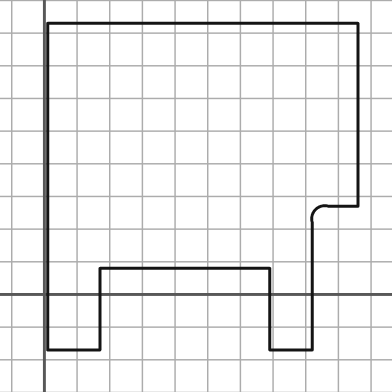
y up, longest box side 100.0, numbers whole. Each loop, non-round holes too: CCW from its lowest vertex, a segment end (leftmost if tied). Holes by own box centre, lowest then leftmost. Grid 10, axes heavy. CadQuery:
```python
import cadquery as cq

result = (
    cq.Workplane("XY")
    .moveTo(1.0, -17.0)
    .lineTo(17.0, -17.0)
    .lineTo(17.0, 8.0)
    .lineTo(69.0, 8.0)
    .lineTo(69.0, -17.0)
    .lineTo(82.0, -17.0)
    .lineTo(82.0, 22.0)
    .threePointArc((83.0, 26.0), (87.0, 27.0))
    .lineTo(96.0, 27.0)
    .lineTo(96.0, 83.0)
    .lineTo(1.0, 83.0)
    .close()
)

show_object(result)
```